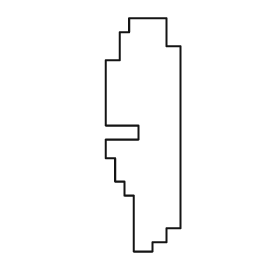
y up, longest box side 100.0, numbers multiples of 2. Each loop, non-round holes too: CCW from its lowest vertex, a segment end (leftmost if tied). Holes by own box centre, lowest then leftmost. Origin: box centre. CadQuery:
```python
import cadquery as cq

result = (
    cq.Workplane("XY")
    .moveTo(-4.0, -50.0)
    .lineTo(4.0, -50.0)
    .lineTo(4.0, -46.0)
    .lineTo(10.0, -46.0)
    .lineTo(10.0, -40.0)
    .lineTo(16.0, -40.0)
    .lineTo(16.0, 38.0)
    .lineTo(10.0, 38.0)
    .lineTo(10.0, 50.0)
    .lineTo(-6.0, 50.0)
    .lineTo(-6.0, 44.0)
    .lineTo(-10.0, 44.0)
    .lineTo(-10.0, 32.0)
    .lineTo(-16.0, 32.0)
    .lineTo(-16.0, 4.0)
    .lineTo(-2.0, 4.0)
    .lineTo(-2.0, -2.0)
    .lineTo(-16.0, -2.0)
    .lineTo(-16.0, -10.0)
    .lineTo(-12.0, -10.0)
    .lineTo(-12.0, -20.0)
    .lineTo(-8.0, -20.0)
    .lineTo(-8.0, -26.0)
    .lineTo(-4.0, -26.0)
    .close()
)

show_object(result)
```